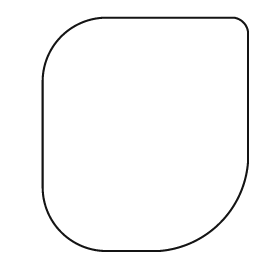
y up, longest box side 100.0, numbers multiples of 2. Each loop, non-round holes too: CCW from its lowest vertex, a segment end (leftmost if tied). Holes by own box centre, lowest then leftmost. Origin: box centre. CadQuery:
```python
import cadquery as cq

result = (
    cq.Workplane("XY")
    .moveTo(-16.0, -50.0)
    .lineTo(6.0, -50.0)
    .threePointArc((32.0, -38.0), (44.0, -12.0))
    .lineTo(44.0, 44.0)
    .threePointArc((42.0, 48.0), (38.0, 50.0))
    .lineTo(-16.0, 50.0)
    .threePointArc((-36.0, 42.0), (-44.0, 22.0))
    .lineTo(-44.0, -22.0)
    .threePointArc((-36.0, -42.0), (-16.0, -50.0))
    .close()
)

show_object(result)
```